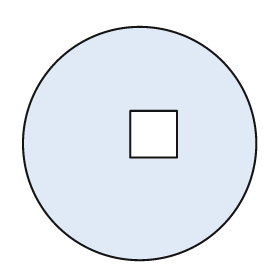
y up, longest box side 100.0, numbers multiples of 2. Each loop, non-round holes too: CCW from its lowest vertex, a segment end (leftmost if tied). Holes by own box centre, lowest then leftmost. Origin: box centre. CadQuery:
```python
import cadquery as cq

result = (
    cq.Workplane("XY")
    .moveTo(0.0, 0.0)
    .circle(50.0)
    .moveTo(-4.0, -6.0)
    .lineTo(16.0, -6.0)
    .lineTo(16.0, 14.0)
    .lineTo(-4.0, 14.0)
    .close()
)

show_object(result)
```